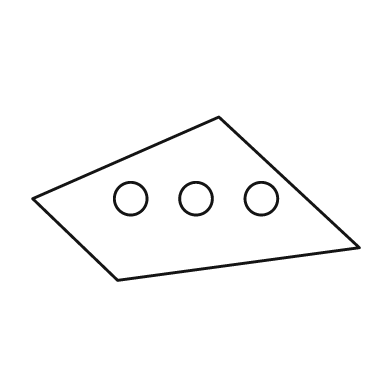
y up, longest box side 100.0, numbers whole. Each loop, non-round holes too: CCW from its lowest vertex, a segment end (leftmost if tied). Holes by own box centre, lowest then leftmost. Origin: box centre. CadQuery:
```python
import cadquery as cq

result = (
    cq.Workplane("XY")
    .moveTo(-24.0, -25.0)
    .lineTo(50.0, -15.0)
    .lineTo(7.0, 25.0)
    .lineTo(-50.0, 0.0)
    .close()
    .moveTo(-20.0, 0.0)
    .circle(5.0)
    .moveTo(0.0, 0.0)
    .circle(5.0)
    .moveTo(20.0, 0.0)
    .circle(5.0)
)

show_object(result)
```